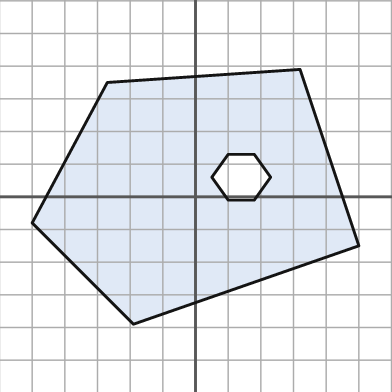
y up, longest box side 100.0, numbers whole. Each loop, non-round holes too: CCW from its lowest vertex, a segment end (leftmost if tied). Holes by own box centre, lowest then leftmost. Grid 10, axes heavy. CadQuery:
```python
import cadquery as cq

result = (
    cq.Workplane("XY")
    .moveTo(-19.0, -39.0)
    .lineTo(50.0, -15.0)
    .lineTo(32.0, 39.0)
    .lineTo(-27.0, 35.0)
    .lineTo(-50.0, -8.0)
    .close()
    .moveTo(10.0, -1.0)
    .lineTo(18.0, -1.0)
    .lineTo(23.0, 6.0)
    .lineTo(18.0, 13.0)
    .lineTo(10.0, 13.0)
    .lineTo(5.0, 6.0)
    .close()
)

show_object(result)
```